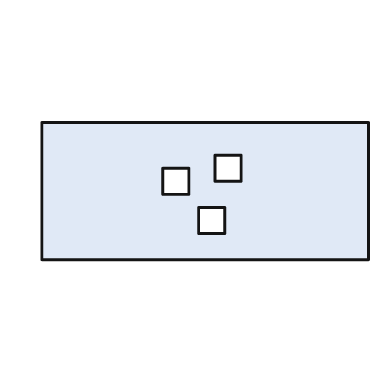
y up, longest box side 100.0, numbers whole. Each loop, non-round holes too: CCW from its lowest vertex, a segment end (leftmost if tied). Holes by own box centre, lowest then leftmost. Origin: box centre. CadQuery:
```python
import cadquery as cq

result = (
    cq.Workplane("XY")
    .moveTo(-50.0, -21.0)
    .lineTo(50.0, -21.0)
    .lineTo(50.0, 21.0)
    .lineTo(-50.0, 21.0)
    .close()
    .moveTo(-2.0, -13.0)
    .lineTo(6.0, -13.0)
    .lineTo(6.0, -5.0)
    .lineTo(-2.0, -5.0)
    .close()
    .moveTo(-13.0, -1.0)
    .lineTo(-5.0, -1.0)
    .lineTo(-5.0, 7.0)
    .lineTo(-13.0, 7.0)
    .close()
    .moveTo(3.0, 3.0)
    .lineTo(11.0, 3.0)
    .lineTo(11.0, 11.0)
    .lineTo(3.0, 11.0)
    .close()
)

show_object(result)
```